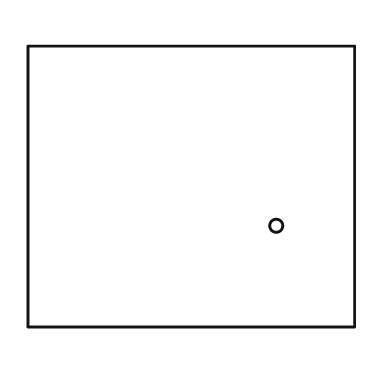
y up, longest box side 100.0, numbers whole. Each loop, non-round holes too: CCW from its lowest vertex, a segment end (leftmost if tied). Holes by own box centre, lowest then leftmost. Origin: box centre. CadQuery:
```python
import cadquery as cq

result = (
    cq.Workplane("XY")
    .moveTo(-50.0, -43.0)
    .lineTo(50.0, -43.0)
    .lineTo(50.0, 43.0)
    .lineTo(-50.0, 43.0)
    .close()
    .moveTo(26.0, -12.0)
    .circle(2.0)
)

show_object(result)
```